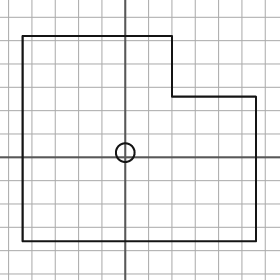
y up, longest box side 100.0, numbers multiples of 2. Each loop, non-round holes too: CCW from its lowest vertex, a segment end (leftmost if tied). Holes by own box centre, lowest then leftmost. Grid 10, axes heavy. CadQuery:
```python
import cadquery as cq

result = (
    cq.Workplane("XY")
    .moveTo(-44.0, -36.0)
    .lineTo(56.0, -36.0)
    .lineTo(56.0, 26.0)
    .lineTo(20.0, 26.0)
    .lineTo(20.0, 52.0)
    .lineTo(-44.0, 52.0)
    .close()
    .moveTo(0.0, 2.0)
    .circle(4.0)
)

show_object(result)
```